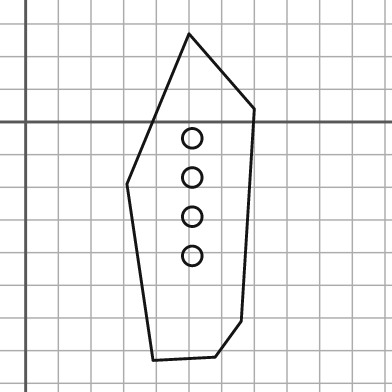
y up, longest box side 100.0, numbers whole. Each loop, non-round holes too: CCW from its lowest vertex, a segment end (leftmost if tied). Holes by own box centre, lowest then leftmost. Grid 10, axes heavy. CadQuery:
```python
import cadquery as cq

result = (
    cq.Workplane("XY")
    .moveTo(39.0, -73.0)
    .lineTo(58.0, -72.0)
    .lineTo(66.0, -61.0)
    .lineTo(70.0, 4.0)
    .lineTo(50.0, 27.0)
    .lineTo(31.0, -19.0)
    .close()
    .moveTo(51.0, -41.0)
    .circle(3.0)
    .moveTo(51.0, -29.0)
    .circle(3.0)
    .moveTo(51.0, -17.0)
    .circle(3.0)
    .moveTo(51.0, -5.0)
    .circle(3.0)
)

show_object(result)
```